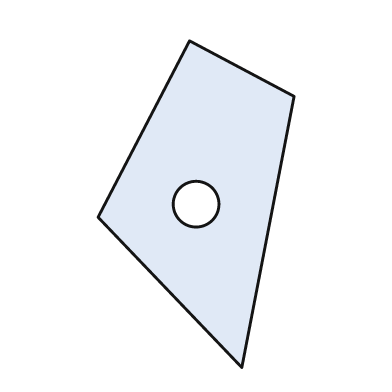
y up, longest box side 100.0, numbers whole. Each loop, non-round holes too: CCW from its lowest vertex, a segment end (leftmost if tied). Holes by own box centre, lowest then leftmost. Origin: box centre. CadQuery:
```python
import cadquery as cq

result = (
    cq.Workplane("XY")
    .moveTo(14.0, -50.0)
    .lineTo(30.0, 33.0)
    .lineTo(-2.0, 50.0)
    .lineTo(-30.0, -4.0)
    .close()
    .moveTo(0.0, 0.0)
    .circle(7.0)
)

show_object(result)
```